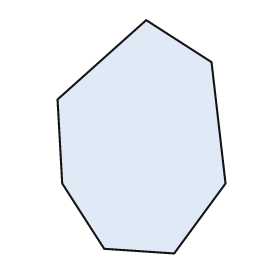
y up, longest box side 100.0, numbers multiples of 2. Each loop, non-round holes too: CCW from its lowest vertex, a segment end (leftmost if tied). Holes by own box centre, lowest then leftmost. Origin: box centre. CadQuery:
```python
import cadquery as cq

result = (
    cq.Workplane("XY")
    .moveTo(14.0, -50.0)
    .lineTo(36.0, -20.0)
    .lineTo(30.0, 32.0)
    .lineTo(2.0, 50.0)
    .lineTo(-36.0, 16.0)
    .lineTo(-34.0, -20.0)
    .lineTo(-16.0, -48.0)
    .close()
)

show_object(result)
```